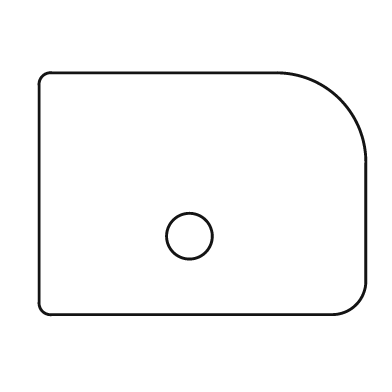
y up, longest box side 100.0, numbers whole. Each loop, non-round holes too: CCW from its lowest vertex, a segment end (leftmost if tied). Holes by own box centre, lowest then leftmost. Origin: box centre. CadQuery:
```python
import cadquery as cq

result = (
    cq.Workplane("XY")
    .moveTo(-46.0, -37.0)
    .lineTo(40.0, -37.0)
    .threePointArc((47.0, -34.0), (50.0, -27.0))
    .lineTo(50.0, 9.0)
    .threePointArc((42.0, 29.0), (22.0, 37.0))
    .lineTo(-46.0, 37.0)
    .threePointArc((-49.0, 36.0), (-50.0, 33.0))
    .lineTo(-50.0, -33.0)
    .threePointArc((-49.0, -36.0), (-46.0, -37.0))
    .close()
    .moveTo(-4.0, -13.0)
    .circle(7.0)
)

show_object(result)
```